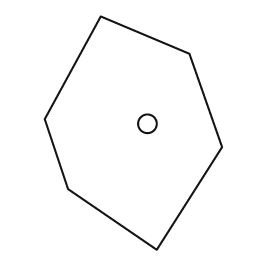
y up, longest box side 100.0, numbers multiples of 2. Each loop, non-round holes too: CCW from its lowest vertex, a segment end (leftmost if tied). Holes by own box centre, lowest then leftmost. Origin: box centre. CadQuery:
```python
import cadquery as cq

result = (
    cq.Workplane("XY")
    .moveTo(10.0, -50.0)
    .lineTo(38.0, -6.0)
    .lineTo(24.0, 34.0)
    .lineTo(-14.0, 50.0)
    .lineTo(-38.0, 6.0)
    .lineTo(-28.0, -24.0)
    .close()
    .moveTo(6.0, 4.0)
    .circle(4.0)
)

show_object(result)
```